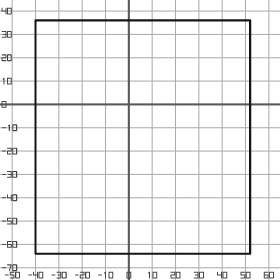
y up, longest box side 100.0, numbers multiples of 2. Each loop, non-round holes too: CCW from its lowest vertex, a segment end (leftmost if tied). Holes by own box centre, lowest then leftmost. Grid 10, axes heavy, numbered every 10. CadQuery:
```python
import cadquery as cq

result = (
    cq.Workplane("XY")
    .moveTo(-40.0, -64.0)
    .lineTo(52.0, -64.0)
    .lineTo(52.0, 36.0)
    .lineTo(-40.0, 36.0)
    .close()
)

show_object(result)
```